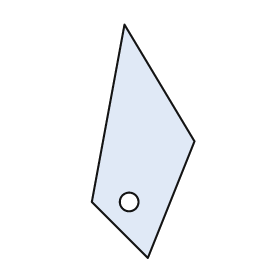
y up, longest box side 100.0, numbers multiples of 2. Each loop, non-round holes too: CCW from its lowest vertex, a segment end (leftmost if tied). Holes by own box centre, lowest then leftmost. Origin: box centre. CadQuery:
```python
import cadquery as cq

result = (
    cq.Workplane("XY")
    .moveTo(2.0, -50.0)
    .lineTo(22.0, 0.0)
    .lineTo(-8.0, 50.0)
    .lineTo(-22.0, -26.0)
    .close()
    .moveTo(-6.0, -26.0)
    .circle(4.0)
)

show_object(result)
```